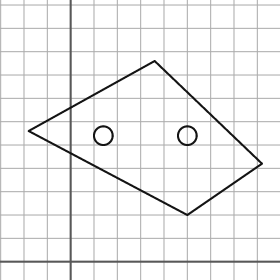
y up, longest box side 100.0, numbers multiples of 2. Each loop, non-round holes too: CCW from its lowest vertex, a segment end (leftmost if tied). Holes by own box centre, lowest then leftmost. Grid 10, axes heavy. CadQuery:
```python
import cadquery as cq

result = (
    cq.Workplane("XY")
    .moveTo(50.0, 20.0)
    .lineTo(82.0, 42.0)
    .lineTo(36.0, 86.0)
    .lineTo(-18.0, 56.0)
    .close()
    .moveTo(14.0, 54.0)
    .circle(4.0)
    .moveTo(50.0, 54.0)
    .circle(4.0)
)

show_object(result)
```